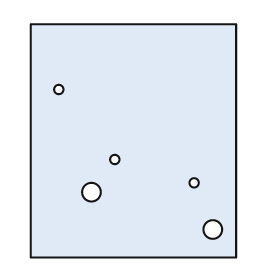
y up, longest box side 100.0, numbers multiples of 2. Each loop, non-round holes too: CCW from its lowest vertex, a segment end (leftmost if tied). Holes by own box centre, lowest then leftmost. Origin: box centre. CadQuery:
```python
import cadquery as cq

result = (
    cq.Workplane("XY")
    .moveTo(-44.0, -50.0)
    .lineTo(44.0, -50.0)
    .lineTo(44.0, 50.0)
    .lineTo(-44.0, 50.0)
    .close()
    .moveTo(34.0, -38.0)
    .circle(4.0)
    .moveTo(-18.0, -22.0)
    .circle(4.0)
    .moveTo(26.0, -18.0)
    .circle(2.0)
    .moveTo(-8.0, -8.0)
    .circle(2.0)
    .moveTo(-32.0, 22.0)
    .circle(2.0)
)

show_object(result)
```